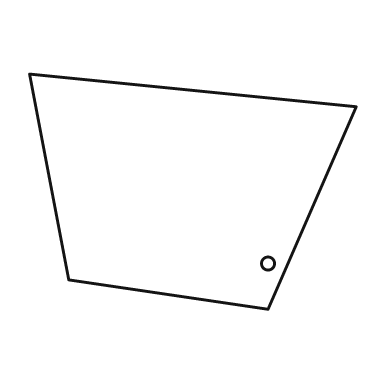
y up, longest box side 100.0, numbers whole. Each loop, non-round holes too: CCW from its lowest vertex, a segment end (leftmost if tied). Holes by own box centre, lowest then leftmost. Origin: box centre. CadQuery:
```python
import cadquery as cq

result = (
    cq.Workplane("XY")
    .moveTo(23.0, -36.0)
    .lineTo(50.0, 26.0)
    .lineTo(-50.0, 36.0)
    .lineTo(-38.0, -27.0)
    .close()
    .moveTo(23.0, -22.0)
    .circle(2.0)
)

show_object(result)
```